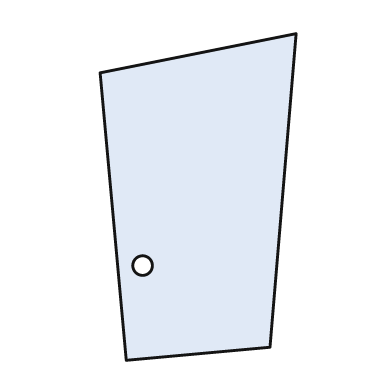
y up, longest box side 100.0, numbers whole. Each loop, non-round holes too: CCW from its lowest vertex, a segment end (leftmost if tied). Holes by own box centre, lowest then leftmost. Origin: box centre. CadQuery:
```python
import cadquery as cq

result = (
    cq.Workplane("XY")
    .moveTo(-22.0, -50.0)
    .lineTo(22.0, -46.0)
    .lineTo(30.0, 50.0)
    .lineTo(-30.0, 38.0)
    .close()
    .moveTo(-17.0, -21.0)
    .circle(3.0)
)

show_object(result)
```